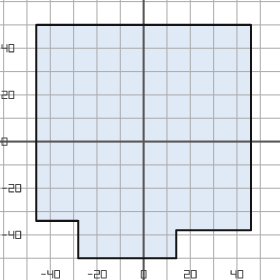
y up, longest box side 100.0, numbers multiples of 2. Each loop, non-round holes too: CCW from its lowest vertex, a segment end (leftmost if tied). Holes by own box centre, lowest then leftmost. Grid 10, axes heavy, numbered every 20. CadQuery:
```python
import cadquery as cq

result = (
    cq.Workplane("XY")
    .moveTo(-28.0, -50.0)
    .lineTo(14.0, -50.0)
    .lineTo(14.0, -38.0)
    .lineTo(46.0, -38.0)
    .lineTo(46.0, 50.0)
    .lineTo(-46.0, 50.0)
    .lineTo(-46.0, -34.0)
    .lineTo(-28.0, -34.0)
    .close()
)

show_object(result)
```